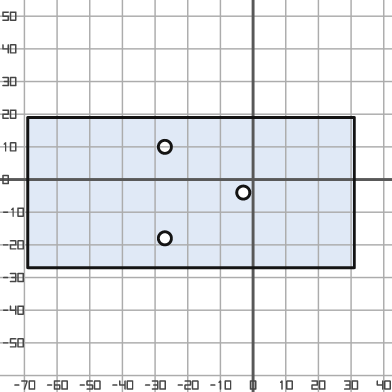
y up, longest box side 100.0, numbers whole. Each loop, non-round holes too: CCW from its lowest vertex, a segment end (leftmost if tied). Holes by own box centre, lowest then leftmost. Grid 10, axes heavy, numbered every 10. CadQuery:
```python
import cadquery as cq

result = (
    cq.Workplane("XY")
    .moveTo(-69.0, -27.0)
    .lineTo(31.0, -27.0)
    .lineTo(31.0, 19.0)
    .lineTo(-69.0, 19.0)
    .close()
    .moveTo(-27.0, -18.0)
    .circle(2.0)
    .moveTo(-3.0, -4.0)
    .circle(2.0)
    .moveTo(-27.0, 10.0)
    .circle(2.0)
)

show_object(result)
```